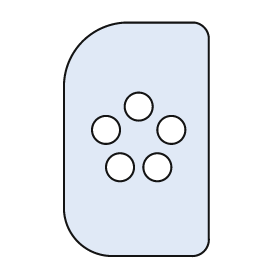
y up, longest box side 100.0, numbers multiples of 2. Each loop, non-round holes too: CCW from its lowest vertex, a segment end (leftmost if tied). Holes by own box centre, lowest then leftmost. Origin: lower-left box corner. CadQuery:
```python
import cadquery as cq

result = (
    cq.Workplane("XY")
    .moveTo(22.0, 0.0)
    .lineTo(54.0, 0.0)
    .threePointArc((60.0, 2.0), (62.0, 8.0))
    .lineTo(62.0, 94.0)
    .threePointArc((60.0, 98.0), (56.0, 100.0))
    .lineTo(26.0, 100.0)
    .threePointArc((8.0, 92.0), (0.0, 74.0))
    .lineTo(0.0, 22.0)
    .threePointArc((6.0, 6.0), (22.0, 0.0))
    .close()
    .moveTo(24.0, 38.0)
    .circle(6.0)
    .moveTo(40.0, 38.0)
    .circle(6.0)
    .moveTo(18.0, 54.0)
    .circle(6.0)
    .moveTo(46.0, 54.0)
    .circle(6.0)
    .moveTo(32.0, 64.0)
    .circle(6.0)
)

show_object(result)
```